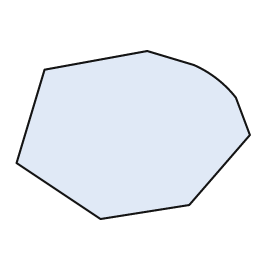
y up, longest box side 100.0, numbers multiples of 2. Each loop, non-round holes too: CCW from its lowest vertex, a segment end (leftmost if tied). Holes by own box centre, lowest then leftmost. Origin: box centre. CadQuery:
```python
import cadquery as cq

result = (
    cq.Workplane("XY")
    .moveTo(-14.0, -36.0)
    .lineTo(24.0, -30.0)
    .lineTo(50.0, 0.0)
    .lineTo(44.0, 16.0)
    .threePointArc((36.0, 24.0), (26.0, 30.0))
    .lineTo(6.0, 36.0)
    .lineTo(-38.0, 28.0)
    .lineTo(-50.0, -12.0)
    .close()
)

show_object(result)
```